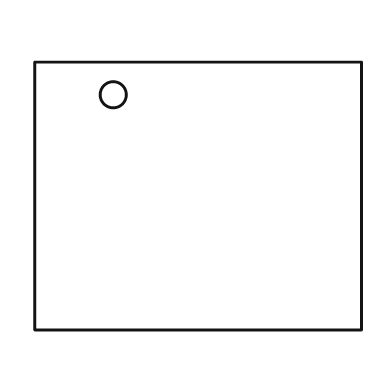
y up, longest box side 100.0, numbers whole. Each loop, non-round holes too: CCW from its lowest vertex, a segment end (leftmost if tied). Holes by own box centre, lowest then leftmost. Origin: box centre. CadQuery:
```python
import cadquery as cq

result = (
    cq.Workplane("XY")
    .moveTo(-50.0, -41.0)
    .lineTo(50.0, -41.0)
    .lineTo(50.0, 41.0)
    .lineTo(-50.0, 41.0)
    .close()
    .moveTo(-26.0, 31.0)
    .circle(4.0)
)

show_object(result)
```